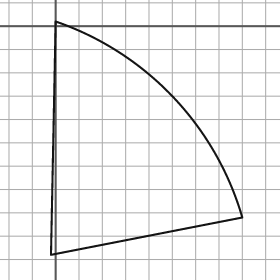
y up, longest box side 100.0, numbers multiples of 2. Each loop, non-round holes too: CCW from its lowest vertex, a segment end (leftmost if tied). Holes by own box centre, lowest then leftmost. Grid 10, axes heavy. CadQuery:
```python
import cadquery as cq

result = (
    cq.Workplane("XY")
    .moveTo(-2.0, -98.0)
    .lineTo(80.0, -82.0)
    .threePointArc((50.0, -30.0), (0.0, 2.0))
    .close()
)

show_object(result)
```